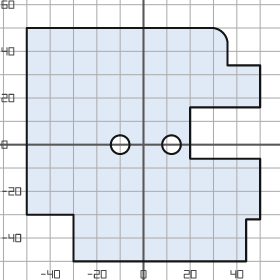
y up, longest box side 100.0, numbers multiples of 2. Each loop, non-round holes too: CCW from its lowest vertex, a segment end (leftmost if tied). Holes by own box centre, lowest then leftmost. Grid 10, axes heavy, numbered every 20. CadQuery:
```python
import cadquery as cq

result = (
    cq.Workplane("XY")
    .moveTo(-30.0, -50.0)
    .lineTo(44.0, -50.0)
    .lineTo(44.0, -32.0)
    .lineTo(50.0, -32.0)
    .lineTo(50.0, -6.0)
    .lineTo(20.0, -6.0)
    .lineTo(20.0, 16.0)
    .lineTo(50.0, 16.0)
    .lineTo(50.0, 34.0)
    .lineTo(36.0, 34.0)
    .lineTo(36.0, 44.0)
    .threePointArc((34.0, 48.0), (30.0, 50.0))
    .lineTo(-50.0, 50.0)
    .lineTo(-50.0, -30.0)
    .lineTo(-30.0, -30.0)
    .close()
    .moveTo(-10.0, 0.0)
    .circle(4.0)
    .moveTo(12.0, 0.0)
    .circle(4.0)
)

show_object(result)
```